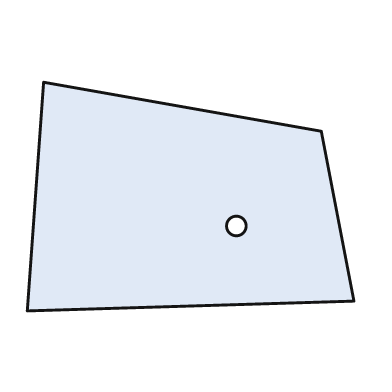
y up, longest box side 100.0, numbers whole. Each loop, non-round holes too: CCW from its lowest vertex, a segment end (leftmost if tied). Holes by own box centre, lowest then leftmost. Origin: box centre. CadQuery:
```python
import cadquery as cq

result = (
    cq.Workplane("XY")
    .moveTo(-50.0, -35.0)
    .lineTo(50.0, -32.0)
    .lineTo(40.0, 20.0)
    .lineTo(-45.0, 35.0)
    .close()
    .moveTo(14.0, -9.0)
    .circle(3.0)
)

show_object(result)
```